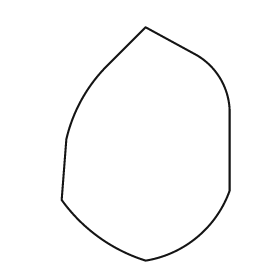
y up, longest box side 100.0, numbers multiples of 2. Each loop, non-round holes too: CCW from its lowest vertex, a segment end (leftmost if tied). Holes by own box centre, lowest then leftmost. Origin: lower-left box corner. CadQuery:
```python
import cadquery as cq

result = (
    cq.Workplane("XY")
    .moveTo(36.0, 0.0)
    .threePointArc((58.0, 10.0), (72.0, 30.0))
    .lineTo(72.0, 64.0)
    .threePointArc((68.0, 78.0), (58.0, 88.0))
    .lineTo(36.0, 100.0)
    .lineTo(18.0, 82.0)
    .threePointArc((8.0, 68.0), (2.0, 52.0))
    .lineTo(0.0, 26.0)
    .threePointArc((16.0, 10.0), (36.0, 0.0))
    .close()
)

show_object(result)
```